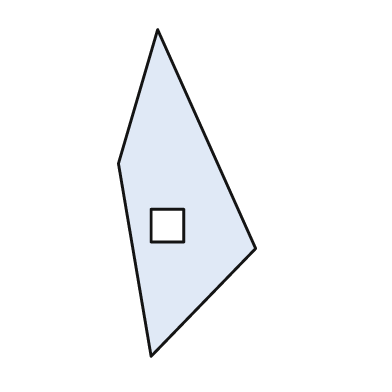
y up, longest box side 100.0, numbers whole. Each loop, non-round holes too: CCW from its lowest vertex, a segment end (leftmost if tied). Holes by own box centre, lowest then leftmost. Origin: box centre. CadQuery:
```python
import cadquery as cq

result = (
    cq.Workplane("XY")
    .moveTo(-11.0, -50.0)
    .lineTo(21.0, -17.0)
    .lineTo(-9.0, 50.0)
    .lineTo(-21.0, 9.0)
    .close()
    .moveTo(-11.0, -15.0)
    .lineTo(-1.0, -15.0)
    .lineTo(-1.0, -5.0)
    .lineTo(-11.0, -5.0)
    .close()
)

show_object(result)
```